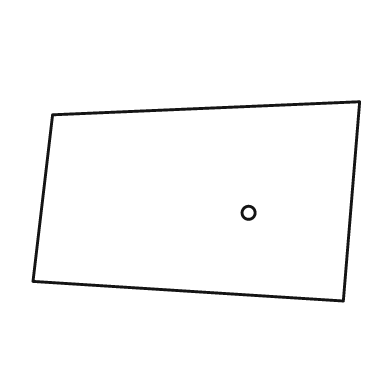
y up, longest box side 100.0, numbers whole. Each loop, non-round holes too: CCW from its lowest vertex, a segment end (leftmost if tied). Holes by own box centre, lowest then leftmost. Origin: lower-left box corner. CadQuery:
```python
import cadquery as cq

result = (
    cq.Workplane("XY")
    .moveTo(95.0, 0.0)
    .lineTo(100.0, 61.0)
    .lineTo(6.0, 57.0)
    .lineTo(0.0, 6.0)
    .close()
    .moveTo(66.0, 27.0)
    .circle(2.0)
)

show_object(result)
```